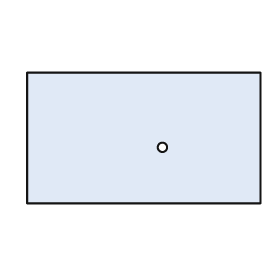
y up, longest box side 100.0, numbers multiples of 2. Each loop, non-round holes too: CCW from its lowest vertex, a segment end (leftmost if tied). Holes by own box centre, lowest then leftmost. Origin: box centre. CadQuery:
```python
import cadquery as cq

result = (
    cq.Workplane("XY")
    .moveTo(-50.0, -28.0)
    .lineTo(50.0, -28.0)
    .lineTo(50.0, 28.0)
    .lineTo(-50.0, 28.0)
    .close()
    .moveTo(8.0, -4.0)
    .circle(2.0)
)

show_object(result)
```